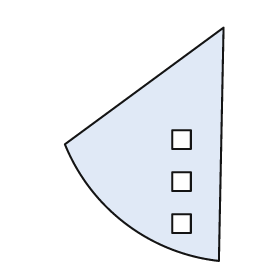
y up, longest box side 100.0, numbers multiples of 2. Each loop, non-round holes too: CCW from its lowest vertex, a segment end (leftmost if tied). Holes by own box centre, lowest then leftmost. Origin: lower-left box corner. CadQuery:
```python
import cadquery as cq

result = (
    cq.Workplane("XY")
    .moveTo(66.0, 0.0)
    .lineTo(68.0, 100.0)
    .lineTo(0.0, 50.0)
    .threePointArc((26.0, 16.0), (66.0, 0.0))
    .close()
    .moveTo(46.0, 12.0)
    .lineTo(54.0, 12.0)
    .lineTo(54.0, 20.0)
    .lineTo(46.0, 20.0)
    .close()
    .moveTo(46.0, 30.0)
    .lineTo(54.0, 30.0)
    .lineTo(54.0, 38.0)
    .lineTo(46.0, 38.0)
    .close()
    .moveTo(46.0, 48.0)
    .lineTo(54.0, 48.0)
    .lineTo(54.0, 56.0)
    .lineTo(46.0, 56.0)
    .close()
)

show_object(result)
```